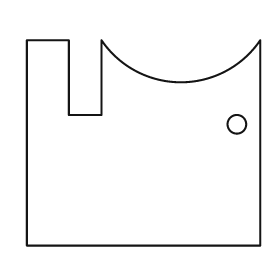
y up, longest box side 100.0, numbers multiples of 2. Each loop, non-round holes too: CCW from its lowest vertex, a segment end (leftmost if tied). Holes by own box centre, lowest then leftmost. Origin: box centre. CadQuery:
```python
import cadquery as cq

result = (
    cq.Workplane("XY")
    .moveTo(-50.0, -44.0)
    .lineTo(50.0, -44.0)
    .lineTo(50.0, 44.0)
    .threePointArc((16.0, 26.0), (-18.0, 44.0))
    .lineTo(-18.0, 12.0)
    .lineTo(-32.0, 12.0)
    .lineTo(-32.0, 44.0)
    .lineTo(-50.0, 44.0)
    .close()
    .moveTo(40.0, 8.0)
    .circle(4.0)
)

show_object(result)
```